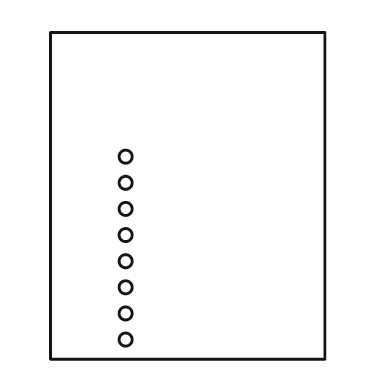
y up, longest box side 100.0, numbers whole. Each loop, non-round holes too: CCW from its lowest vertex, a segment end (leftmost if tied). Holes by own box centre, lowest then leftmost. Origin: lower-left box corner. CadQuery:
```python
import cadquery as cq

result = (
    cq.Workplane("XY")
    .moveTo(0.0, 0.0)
    .lineTo(84.0, 0.0)
    .lineTo(84.0, 100.0)
    .lineTo(0.0, 100.0)
    .close()
    .moveTo(23.0, 6.0)
    .circle(2.0)
    .moveTo(23.0, 14.0)
    .circle(2.0)
    .moveTo(23.0, 22.0)
    .circle(2.0)
    .moveTo(23.0, 30.0)
    .circle(2.0)
    .moveTo(23.0, 38.0)
    .circle(2.0)
    .moveTo(23.0, 46.0)
    .circle(2.0)
    .moveTo(23.0, 54.0)
    .circle(2.0)
    .moveTo(23.0, 62.0)
    .circle(2.0)
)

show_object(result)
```